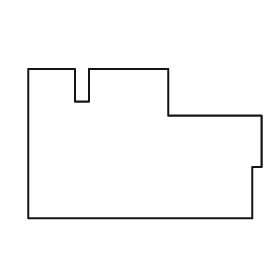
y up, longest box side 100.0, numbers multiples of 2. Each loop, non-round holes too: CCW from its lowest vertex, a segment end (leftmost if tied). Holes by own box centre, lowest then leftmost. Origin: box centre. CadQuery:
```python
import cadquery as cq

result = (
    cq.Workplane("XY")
    .moveTo(-50.0, -32.0)
    .lineTo(46.0, -32.0)
    .lineTo(46.0, -10.0)
    .lineTo(50.0, -10.0)
    .lineTo(50.0, 12.0)
    .lineTo(10.0, 12.0)
    .lineTo(10.0, 32.0)
    .lineTo(-24.0, 32.0)
    .lineTo(-24.0, 18.0)
    .lineTo(-30.0, 18.0)
    .lineTo(-30.0, 32.0)
    .lineTo(-50.0, 32.0)
    .close()
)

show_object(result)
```